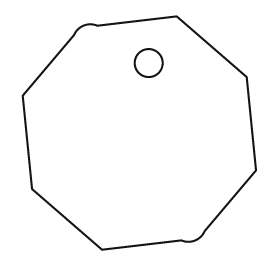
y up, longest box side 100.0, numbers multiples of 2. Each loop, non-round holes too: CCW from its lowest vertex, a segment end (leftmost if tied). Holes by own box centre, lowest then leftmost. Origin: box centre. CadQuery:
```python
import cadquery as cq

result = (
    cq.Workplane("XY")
    .moveTo(-16.0, -50.0)
    .lineTo(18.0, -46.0)
    .threePointArc((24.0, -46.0), (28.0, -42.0))
    .lineTo(50.0, -16.0)
    .lineTo(46.0, 24.0)
    .lineTo(16.0, 50.0)
    .lineTo(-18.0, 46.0)
    .threePointArc((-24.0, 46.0), (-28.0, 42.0))
    .lineTo(-50.0, 16.0)
    .lineTo(-46.0, -24.0)
    .close()
    .moveTo(4.0, 30.0)
    .circle(6.0)
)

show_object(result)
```